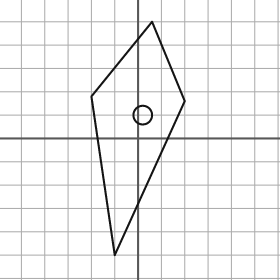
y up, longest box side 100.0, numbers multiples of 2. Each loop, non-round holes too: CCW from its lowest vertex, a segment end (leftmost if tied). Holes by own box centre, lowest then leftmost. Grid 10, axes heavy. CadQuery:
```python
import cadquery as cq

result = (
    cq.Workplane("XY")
    .moveTo(-10.0, -50.0)
    .lineTo(20.0, 16.0)
    .lineTo(6.0, 50.0)
    .lineTo(-20.0, 18.0)
    .close()
    .moveTo(2.0, 10.0)
    .circle(4.0)
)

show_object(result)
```